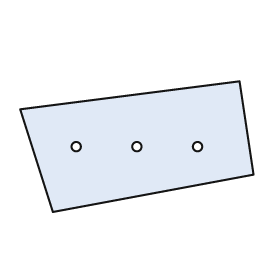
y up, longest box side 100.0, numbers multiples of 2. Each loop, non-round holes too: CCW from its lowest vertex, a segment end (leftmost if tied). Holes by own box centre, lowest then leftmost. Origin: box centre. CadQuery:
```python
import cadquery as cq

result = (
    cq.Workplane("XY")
    .moveTo(-36.0, -28.0)
    .lineTo(50.0, -12.0)
    .lineTo(44.0, 28.0)
    .lineTo(-50.0, 16.0)
    .close()
    .moveTo(-26.0, 0.0)
    .circle(2.0)
    .moveTo(0.0, 0.0)
    .circle(2.0)
    .moveTo(26.0, 0.0)
    .circle(2.0)
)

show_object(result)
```